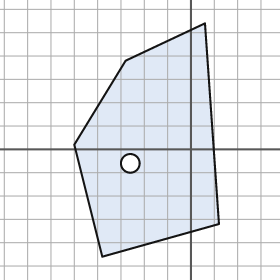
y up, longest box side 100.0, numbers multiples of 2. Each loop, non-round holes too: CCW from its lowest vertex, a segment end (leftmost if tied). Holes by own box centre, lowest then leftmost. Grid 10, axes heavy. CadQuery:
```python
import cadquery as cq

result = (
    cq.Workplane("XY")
    .moveTo(-38.0, -46.0)
    .lineTo(12.0, -32.0)
    .lineTo(6.0, 54.0)
    .lineTo(-28.0, 38.0)
    .lineTo(-50.0, 2.0)
    .close()
    .moveTo(-26.0, -6.0)
    .circle(4.0)
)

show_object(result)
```